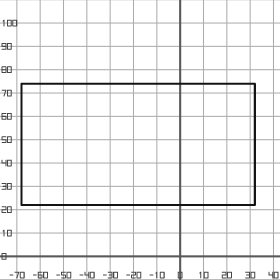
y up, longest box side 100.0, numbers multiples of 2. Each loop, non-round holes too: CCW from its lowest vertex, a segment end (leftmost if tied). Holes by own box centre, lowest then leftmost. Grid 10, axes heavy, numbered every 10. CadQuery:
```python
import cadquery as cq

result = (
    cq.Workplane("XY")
    .moveTo(-68.0, 22.0)
    .lineTo(32.0, 22.0)
    .lineTo(32.0, 74.0)
    .lineTo(-68.0, 74.0)
    .close()
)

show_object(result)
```